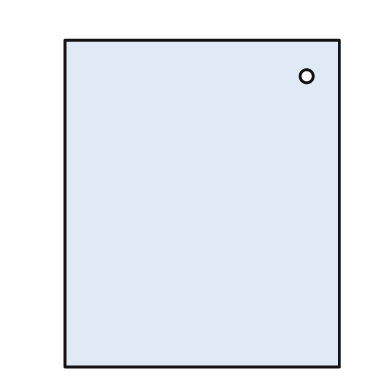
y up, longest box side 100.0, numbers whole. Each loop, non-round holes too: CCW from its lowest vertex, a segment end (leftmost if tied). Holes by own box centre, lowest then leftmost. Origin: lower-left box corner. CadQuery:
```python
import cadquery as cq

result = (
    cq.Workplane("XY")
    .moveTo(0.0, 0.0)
    .lineTo(84.0, 0.0)
    .lineTo(84.0, 100.0)
    .lineTo(0.0, 100.0)
    .close()
    .moveTo(74.0, 89.0)
    .circle(2.0)
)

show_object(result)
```